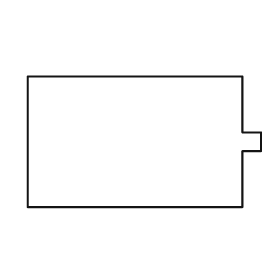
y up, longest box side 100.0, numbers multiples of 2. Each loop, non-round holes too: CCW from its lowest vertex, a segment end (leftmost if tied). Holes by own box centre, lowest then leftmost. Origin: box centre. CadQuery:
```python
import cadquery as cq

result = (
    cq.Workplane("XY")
    .moveTo(-50.0, -28.0)
    .lineTo(42.0, -28.0)
    .lineTo(42.0, -4.0)
    .lineTo(50.0, -4.0)
    .lineTo(50.0, 4.0)
    .lineTo(42.0, 4.0)
    .lineTo(42.0, 28.0)
    .lineTo(-50.0, 28.0)
    .close()
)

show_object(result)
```